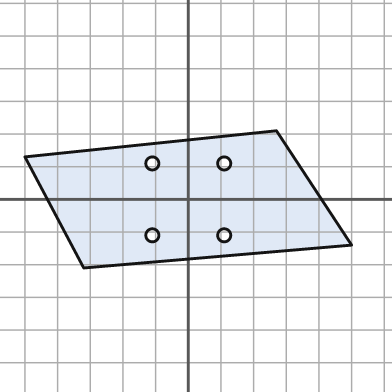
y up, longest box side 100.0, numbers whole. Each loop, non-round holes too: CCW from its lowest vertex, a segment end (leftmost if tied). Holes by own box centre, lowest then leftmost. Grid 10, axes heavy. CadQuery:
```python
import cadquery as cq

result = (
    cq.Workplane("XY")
    .moveTo(-32.0, -21.0)
    .lineTo(50.0, -14.0)
    .lineTo(27.0, 21.0)
    .lineTo(-50.0, 13.0)
    .close()
    .moveTo(-11.0, -11.0)
    .circle(2.0)
    .moveTo(11.0, -11.0)
    .circle(2.0)
    .moveTo(-11.0, 11.0)
    .circle(2.0)
    .moveTo(11.0, 11.0)
    .circle(2.0)
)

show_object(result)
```